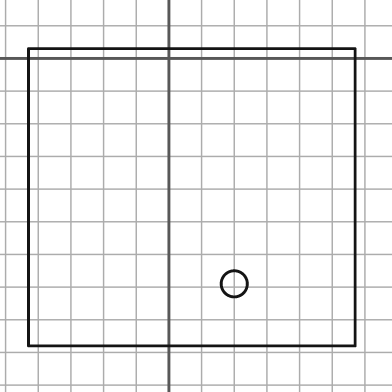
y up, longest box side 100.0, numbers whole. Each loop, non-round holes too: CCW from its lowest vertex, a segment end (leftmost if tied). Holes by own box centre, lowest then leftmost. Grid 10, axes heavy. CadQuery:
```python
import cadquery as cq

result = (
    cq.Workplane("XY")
    .moveTo(-43.0, -88.0)
    .lineTo(57.0, -88.0)
    .lineTo(57.0, 3.0)
    .lineTo(-43.0, 3.0)
    .close()
    .moveTo(20.0, -69.0)
    .circle(4.0)
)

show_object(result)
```